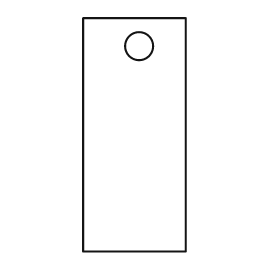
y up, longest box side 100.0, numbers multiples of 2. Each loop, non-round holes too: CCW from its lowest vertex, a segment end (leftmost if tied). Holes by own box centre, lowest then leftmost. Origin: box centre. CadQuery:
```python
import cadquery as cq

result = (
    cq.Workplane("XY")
    .moveTo(-22.0, -50.0)
    .lineTo(22.0, -50.0)
    .lineTo(22.0, 50.0)
    .lineTo(-22.0, 50.0)
    .close()
    .moveTo(2.0, 38.0)
    .circle(6.0)
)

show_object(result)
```